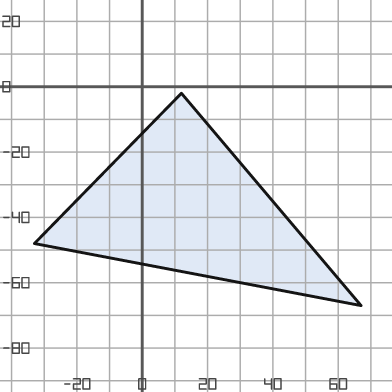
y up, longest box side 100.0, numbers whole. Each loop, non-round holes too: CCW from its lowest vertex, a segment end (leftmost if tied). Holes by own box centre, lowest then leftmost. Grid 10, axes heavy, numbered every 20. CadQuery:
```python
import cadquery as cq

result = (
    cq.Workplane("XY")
    .moveTo(67.0, -67.0)
    .lineTo(12.0, -2.0)
    .lineTo(-33.0, -48.0)
    .close()
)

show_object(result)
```